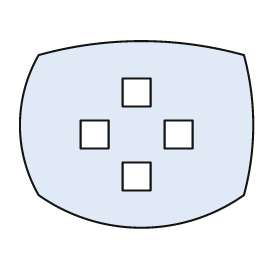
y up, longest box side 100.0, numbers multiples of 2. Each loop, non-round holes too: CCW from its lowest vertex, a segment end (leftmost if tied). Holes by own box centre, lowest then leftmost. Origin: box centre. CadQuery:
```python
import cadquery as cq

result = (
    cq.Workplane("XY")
    .moveTo(-42.0, -26.0)
    .threePointArc((2.0, -40.0), (46.0, -26.0))
    .threePointArc((50.0, 4.0), (46.0, 34.0))
    .threePointArc((2.0, 40.0), (-42.0, 34.0))
    .threePointArc((-50.0, 4.0), (-42.0, -26.0))
    .close()
    .moveTo(-6.0, -24.0)
    .lineTo(6.0, -24.0)
    .lineTo(6.0, -12.0)
    .lineTo(-6.0, -12.0)
    .close()
    .moveTo(-24.0, -6.0)
    .lineTo(-12.0, -6.0)
    .lineTo(-12.0, 6.0)
    .lineTo(-24.0, 6.0)
    .close()
    .moveTo(12.0, -6.0)
    .lineTo(24.0, -6.0)
    .lineTo(24.0, 6.0)
    .lineTo(12.0, 6.0)
    .close()
    .moveTo(-6.0, 12.0)
    .lineTo(6.0, 12.0)
    .lineTo(6.0, 24.0)
    .lineTo(-6.0, 24.0)
    .close()
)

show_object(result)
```